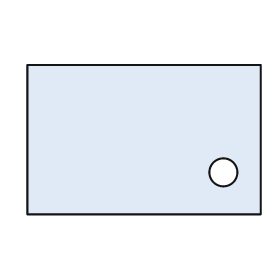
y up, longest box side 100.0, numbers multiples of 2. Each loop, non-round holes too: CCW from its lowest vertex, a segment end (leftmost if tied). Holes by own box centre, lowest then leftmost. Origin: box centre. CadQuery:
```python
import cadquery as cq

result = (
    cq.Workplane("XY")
    .moveTo(-50.0, -32.0)
    .lineTo(50.0, -32.0)
    .lineTo(50.0, 32.0)
    .lineTo(-50.0, 32.0)
    .close()
    .moveTo(34.0, -14.0)
    .circle(6.0)
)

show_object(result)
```